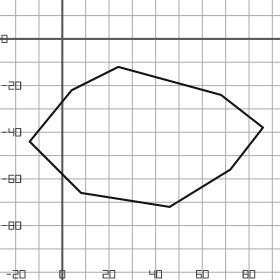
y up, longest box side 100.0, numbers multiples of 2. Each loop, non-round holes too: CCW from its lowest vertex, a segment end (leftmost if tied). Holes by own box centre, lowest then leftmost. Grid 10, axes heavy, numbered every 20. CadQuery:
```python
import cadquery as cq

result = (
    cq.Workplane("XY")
    .moveTo(46.0, -72.0)
    .lineTo(72.0, -56.0)
    .lineTo(86.0, -38.0)
    .lineTo(68.0, -24.0)
    .lineTo(24.0, -12.0)
    .lineTo(4.0, -22.0)
    .lineTo(-14.0, -44.0)
    .lineTo(8.0, -66.0)
    .close()
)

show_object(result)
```